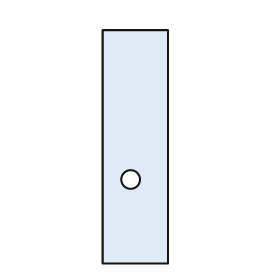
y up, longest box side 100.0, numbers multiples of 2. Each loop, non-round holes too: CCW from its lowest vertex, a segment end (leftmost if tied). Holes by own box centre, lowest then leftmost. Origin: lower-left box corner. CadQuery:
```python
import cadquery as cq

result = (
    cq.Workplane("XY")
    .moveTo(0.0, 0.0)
    .lineTo(28.0, 0.0)
    .lineTo(28.0, 100.0)
    .lineTo(0.0, 100.0)
    .close()
    .moveTo(12.0, 36.0)
    .circle(4.0)
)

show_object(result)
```